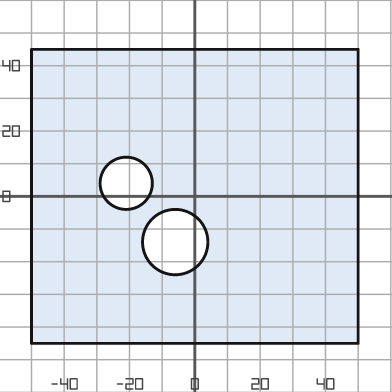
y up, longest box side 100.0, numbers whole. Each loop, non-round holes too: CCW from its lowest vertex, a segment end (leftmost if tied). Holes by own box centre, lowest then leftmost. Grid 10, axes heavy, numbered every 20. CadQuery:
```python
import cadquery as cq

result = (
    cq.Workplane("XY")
    .moveTo(-50.0, -45.0)
    .lineTo(50.0, -45.0)
    .lineTo(50.0, 45.0)
    .lineTo(-50.0, 45.0)
    .close()
    .moveTo(-6.0, -14.0)
    .circle(10.0)
    .moveTo(-21.0, 4.0)
    .circle(8.0)
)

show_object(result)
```